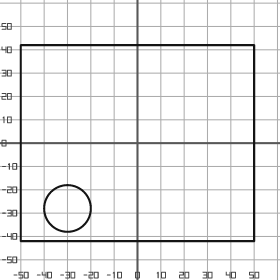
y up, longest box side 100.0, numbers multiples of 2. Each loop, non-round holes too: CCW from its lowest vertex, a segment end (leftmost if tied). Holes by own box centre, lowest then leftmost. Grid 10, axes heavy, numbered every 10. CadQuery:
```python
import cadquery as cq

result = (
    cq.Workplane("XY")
    .moveTo(-50.0, -42.0)
    .lineTo(50.0, -42.0)
    .lineTo(50.0, 42.0)
    .lineTo(-50.0, 42.0)
    .close()
    .moveTo(-30.0, -28.0)
    .circle(10.0)
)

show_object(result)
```